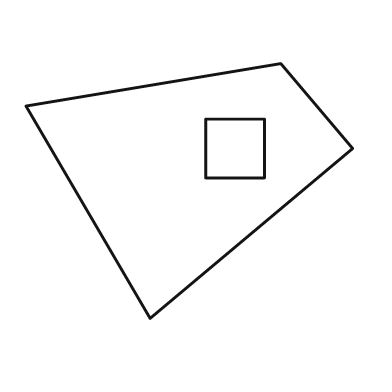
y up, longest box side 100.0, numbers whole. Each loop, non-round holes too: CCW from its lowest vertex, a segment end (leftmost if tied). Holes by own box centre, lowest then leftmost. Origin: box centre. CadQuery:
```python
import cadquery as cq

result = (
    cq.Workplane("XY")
    .moveTo(-12.0, -39.0)
    .lineTo(50.0, 13.0)
    .lineTo(28.0, 39.0)
    .lineTo(-50.0, 26.0)
    .close()
    .moveTo(5.0, 4.0)
    .lineTo(23.0, 4.0)
    .lineTo(23.0, 22.0)
    .lineTo(5.0, 22.0)
    .close()
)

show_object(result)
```